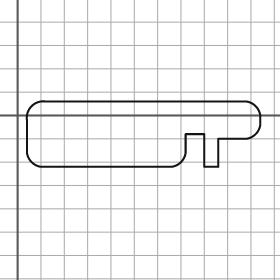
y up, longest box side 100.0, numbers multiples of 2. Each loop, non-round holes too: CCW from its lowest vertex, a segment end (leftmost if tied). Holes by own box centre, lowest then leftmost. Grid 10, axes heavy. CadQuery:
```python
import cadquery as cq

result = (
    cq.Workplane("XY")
    .moveTo(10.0, -22.0)
    .lineTo(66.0, -22.0)
    .threePointArc((70.0, -20.0), (72.0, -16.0))
    .lineTo(72.0, -8.0)
    .lineTo(80.0, -8.0)
    .lineTo(80.0, -22.0)
    .lineTo(86.0, -22.0)
    .lineTo(86.0, -10.0)
    .lineTo(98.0, -10.0)
    .threePointArc((102.0, -8.0), (104.0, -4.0))
    .lineTo(104.0, 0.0)
    .threePointArc((102.0, 4.0), (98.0, 6.0))
    .lineTo(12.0, 6.0)
    .threePointArc((6.0, 4.0), (4.0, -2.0))
    .lineTo(4.0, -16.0)
    .threePointArc((6.0, -20.0), (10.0, -22.0))
    .close()
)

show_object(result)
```